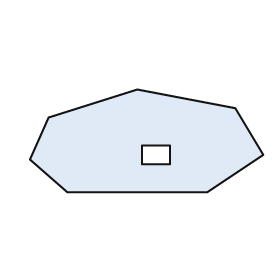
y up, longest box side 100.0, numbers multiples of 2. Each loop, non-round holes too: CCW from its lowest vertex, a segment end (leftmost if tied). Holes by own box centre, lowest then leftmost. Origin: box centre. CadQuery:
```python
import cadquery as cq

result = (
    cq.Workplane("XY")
    .moveTo(-34.0, -22.0)
    .lineTo(26.0, -22.0)
    .lineTo(50.0, -6.0)
    .lineTo(38.0, 14.0)
    .lineTo(-4.0, 22.0)
    .lineTo(-42.0, 10.0)
    .lineTo(-50.0, -8.0)
    .close()
    .moveTo(-2.0, -10.0)
    .lineTo(10.0, -10.0)
    .lineTo(10.0, -2.0)
    .lineTo(-2.0, -2.0)
    .close()
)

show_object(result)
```